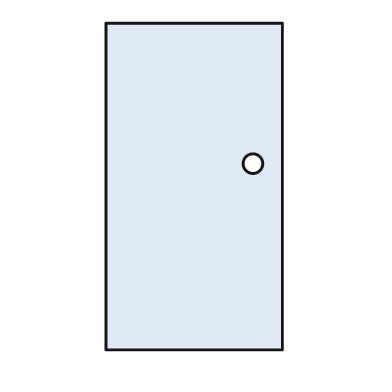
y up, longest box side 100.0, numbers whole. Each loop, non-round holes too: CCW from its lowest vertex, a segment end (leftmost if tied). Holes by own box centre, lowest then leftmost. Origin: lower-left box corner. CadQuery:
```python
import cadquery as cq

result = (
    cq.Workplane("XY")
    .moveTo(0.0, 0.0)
    .lineTo(54.0, 0.0)
    .lineTo(54.0, 100.0)
    .lineTo(0.0, 100.0)
    .close()
    .moveTo(45.0, 57.0)
    .circle(3.0)
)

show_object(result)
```